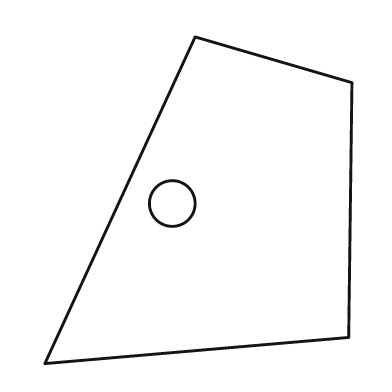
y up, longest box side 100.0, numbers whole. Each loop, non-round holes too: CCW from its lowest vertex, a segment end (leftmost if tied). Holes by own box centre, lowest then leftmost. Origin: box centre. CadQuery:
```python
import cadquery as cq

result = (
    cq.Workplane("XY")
    .moveTo(-47.0, -50.0)
    .lineTo(46.0, -42.0)
    .lineTo(47.0, 36.0)
    .lineTo(-1.0, 50.0)
    .close()
    .moveTo(-8.0, -1.0)
    .circle(7.0)
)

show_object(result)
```